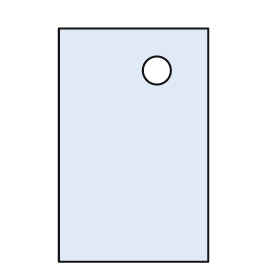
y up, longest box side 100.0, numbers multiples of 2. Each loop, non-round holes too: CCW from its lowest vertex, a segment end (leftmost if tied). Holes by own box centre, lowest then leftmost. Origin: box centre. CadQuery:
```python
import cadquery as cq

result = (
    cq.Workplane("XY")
    .moveTo(-32.0, -50.0)
    .lineTo(32.0, -50.0)
    .lineTo(32.0, 50.0)
    .lineTo(-32.0, 50.0)
    .close()
    .moveTo(10.0, 32.0)
    .circle(6.0)
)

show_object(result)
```